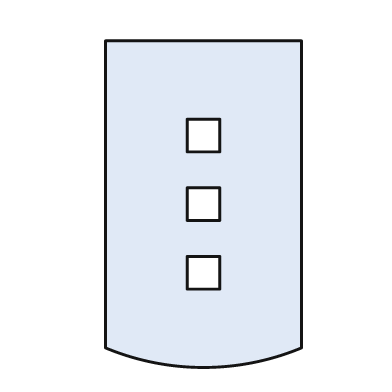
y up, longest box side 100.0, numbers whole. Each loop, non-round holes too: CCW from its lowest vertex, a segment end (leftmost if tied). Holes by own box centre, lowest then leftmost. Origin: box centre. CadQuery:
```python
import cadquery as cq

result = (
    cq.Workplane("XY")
    .moveTo(-30.0, -44.0)
    .threePointArc((0.0, -50.0), (30.0, -44.0))
    .lineTo(30.0, 50.0)
    .lineTo(-30.0, 50.0)
    .close()
    .moveTo(-5.0, -26.0)
    .lineTo(5.0, -26.0)
    .lineTo(5.0, -16.0)
    .lineTo(-5.0, -16.0)
    .close()
    .moveTo(-5.0, -5.0)
    .lineTo(5.0, -5.0)
    .lineTo(5.0, 5.0)
    .lineTo(-5.0, 5.0)
    .close()
    .moveTo(-5.0, 16.0)
    .lineTo(5.0, 16.0)
    .lineTo(5.0, 26.0)
    .lineTo(-5.0, 26.0)
    .close()
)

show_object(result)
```